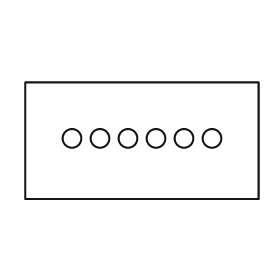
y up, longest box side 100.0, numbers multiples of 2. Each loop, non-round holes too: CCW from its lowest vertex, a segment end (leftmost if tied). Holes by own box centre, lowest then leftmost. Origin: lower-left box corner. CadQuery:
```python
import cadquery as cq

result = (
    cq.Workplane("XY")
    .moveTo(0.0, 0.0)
    .lineTo(100.0, 0.0)
    .lineTo(100.0, 50.0)
    .lineTo(0.0, 50.0)
    .close()
    .moveTo(20.0, 26.0)
    .circle(4.0)
    .moveTo(32.0, 26.0)
    .circle(4.0)
    .moveTo(44.0, 26.0)
    .circle(4.0)
    .moveTo(56.0, 26.0)
    .circle(4.0)
    .moveTo(68.0, 26.0)
    .circle(4.0)
    .moveTo(80.0, 26.0)
    .circle(4.0)
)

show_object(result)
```